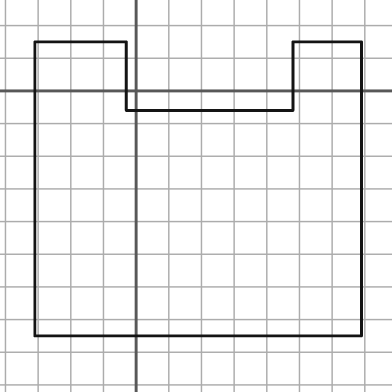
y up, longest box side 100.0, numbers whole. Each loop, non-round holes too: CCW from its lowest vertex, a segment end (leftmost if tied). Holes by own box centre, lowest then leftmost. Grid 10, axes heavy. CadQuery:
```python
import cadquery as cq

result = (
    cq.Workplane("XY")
    .moveTo(-31.0, -75.0)
    .lineTo(69.0, -75.0)
    .lineTo(69.0, 15.0)
    .lineTo(48.0, 15.0)
    .lineTo(48.0, -6.0)
    .lineTo(-3.0, -6.0)
    .lineTo(-3.0, 15.0)
    .lineTo(-31.0, 15.0)
    .close()
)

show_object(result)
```